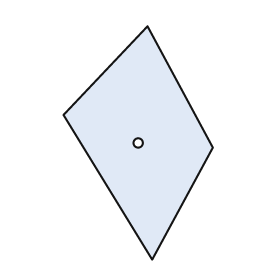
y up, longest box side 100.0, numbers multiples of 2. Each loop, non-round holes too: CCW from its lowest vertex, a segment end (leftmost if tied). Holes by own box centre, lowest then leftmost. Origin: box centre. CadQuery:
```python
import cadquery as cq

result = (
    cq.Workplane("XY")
    .moveTo(6.0, -50.0)
    .lineTo(32.0, -2.0)
    .lineTo(4.0, 50.0)
    .lineTo(-32.0, 12.0)
    .close()
    .moveTo(0.0, 0.0)
    .circle(2.0)
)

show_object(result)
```